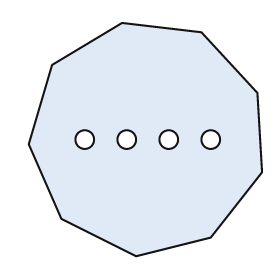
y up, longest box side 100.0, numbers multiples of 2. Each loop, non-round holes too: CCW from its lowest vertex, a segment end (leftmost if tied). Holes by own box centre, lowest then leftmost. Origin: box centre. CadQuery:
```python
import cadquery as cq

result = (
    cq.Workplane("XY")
    .moveTo(-4.0, -50.0)
    .lineTo(28.0, -42.0)
    .lineTo(50.0, -14.0)
    .lineTo(48.0, 20.0)
    .lineTo(24.0, 46.0)
    .lineTo(-10.0, 50.0)
    .lineTo(-40.0, 32.0)
    .lineTo(-50.0, -2.0)
    .lineTo(-36.0, -34.0)
    .close()
    .moveTo(-26.0, 0.0)
    .circle(4.0)
    .moveTo(-8.0, 0.0)
    .circle(4.0)
    .moveTo(10.0, 0.0)
    .circle(4.0)
    .moveTo(28.0, 0.0)
    .circle(4.0)
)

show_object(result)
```